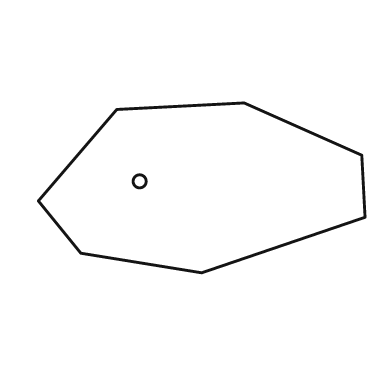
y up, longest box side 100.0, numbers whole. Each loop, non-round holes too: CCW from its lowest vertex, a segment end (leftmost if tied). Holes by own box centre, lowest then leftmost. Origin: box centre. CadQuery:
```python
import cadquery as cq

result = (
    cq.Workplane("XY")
    .moveTo(0.0, -26.0)
    .lineTo(50.0, -9.0)
    .lineTo(49.0, 10.0)
    .lineTo(13.0, 26.0)
    .lineTo(-26.0, 24.0)
    .lineTo(-50.0, -4.0)
    .lineTo(-37.0, -20.0)
    .close()
    .moveTo(-19.0, 2.0)
    .circle(2.0)
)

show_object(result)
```